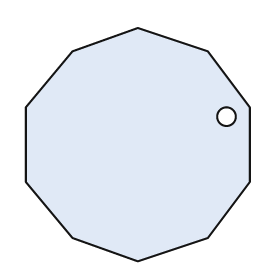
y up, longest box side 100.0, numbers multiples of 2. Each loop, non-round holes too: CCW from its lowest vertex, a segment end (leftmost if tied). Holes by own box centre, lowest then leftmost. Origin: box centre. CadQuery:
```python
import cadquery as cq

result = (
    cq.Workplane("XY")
    .moveTo(0.0, -50.0)
    .lineTo(30.0, -40.0)
    .lineTo(48.0, -16.0)
    .lineTo(48.0, 16.0)
    .lineTo(30.0, 40.0)
    .lineTo(0.0, 50.0)
    .lineTo(-28.0, 40.0)
    .lineTo(-48.0, 16.0)
    .lineTo(-48.0, -16.0)
    .lineTo(-28.0, -40.0)
    .close()
    .moveTo(38.0, 12.0)
    .circle(4.0)
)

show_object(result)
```